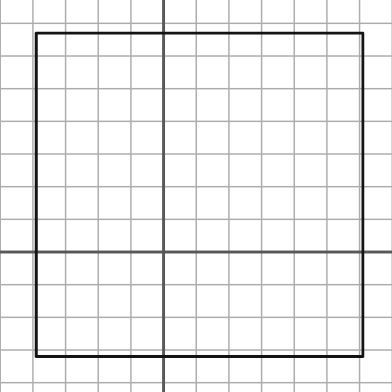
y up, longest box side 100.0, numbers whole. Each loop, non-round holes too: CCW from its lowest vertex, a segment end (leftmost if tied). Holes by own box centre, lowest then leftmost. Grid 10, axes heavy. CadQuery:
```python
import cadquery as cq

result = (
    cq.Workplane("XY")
    .moveTo(-39.0, -32.0)
    .lineTo(61.0, -32.0)
    .lineTo(61.0, 67.0)
    .lineTo(-39.0, 67.0)
    .close()
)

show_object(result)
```